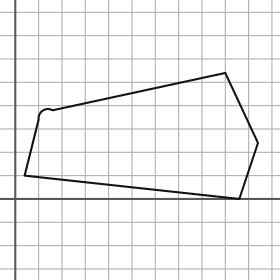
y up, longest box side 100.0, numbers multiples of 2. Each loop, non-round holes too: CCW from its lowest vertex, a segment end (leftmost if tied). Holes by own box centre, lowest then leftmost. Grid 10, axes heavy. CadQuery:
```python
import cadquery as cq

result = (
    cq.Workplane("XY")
    .moveTo(96.0, 0.0)
    .lineTo(104.0, 24.0)
    .lineTo(90.0, 54.0)
    .lineTo(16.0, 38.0)
    .threePointArc((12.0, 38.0), (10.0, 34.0))
    .lineTo(4.0, 10.0)
    .close()
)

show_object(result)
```